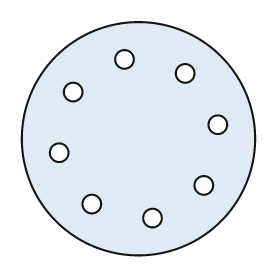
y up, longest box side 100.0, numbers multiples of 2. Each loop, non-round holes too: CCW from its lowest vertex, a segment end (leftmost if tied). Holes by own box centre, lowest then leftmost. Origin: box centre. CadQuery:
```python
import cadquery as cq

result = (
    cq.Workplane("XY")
    .moveTo(0.0, 0.0)
    .circle(50.0)
    .moveTo(6.0, -34.0)
    .circle(4.0)
    .moveTo(-20.0, -28.0)
    .circle(4.0)
    .moveTo(28.0, -20.0)
    .circle(4.0)
    .moveTo(-34.0, -6.0)
    .circle(4.0)
    .moveTo(34.0, 6.0)
    .circle(4.0)
    .moveTo(-28.0, 20.0)
    .circle(4.0)
    .moveTo(20.0, 28.0)
    .circle(4.0)
    .moveTo(-6.0, 34.0)
    .circle(4.0)
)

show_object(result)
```